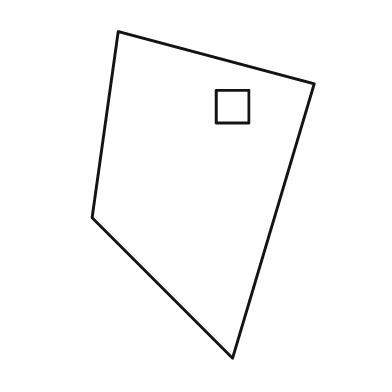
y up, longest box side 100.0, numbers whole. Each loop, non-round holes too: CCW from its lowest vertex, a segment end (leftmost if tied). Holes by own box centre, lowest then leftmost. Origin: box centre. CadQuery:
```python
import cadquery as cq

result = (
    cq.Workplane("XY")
    .moveTo(9.0, -50.0)
    .lineTo(34.0, 34.0)
    .lineTo(-26.0, 50.0)
    .lineTo(-34.0, -7.0)
    .close()
    .moveTo(4.0, 22.0)
    .lineTo(14.0, 22.0)
    .lineTo(14.0, 32.0)
    .lineTo(4.0, 32.0)
    .close()
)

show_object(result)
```